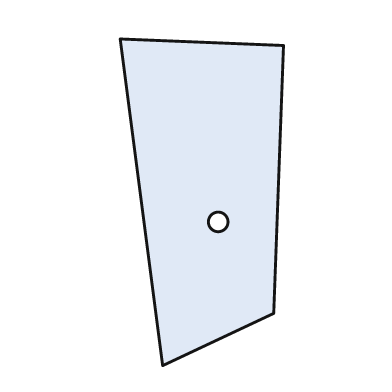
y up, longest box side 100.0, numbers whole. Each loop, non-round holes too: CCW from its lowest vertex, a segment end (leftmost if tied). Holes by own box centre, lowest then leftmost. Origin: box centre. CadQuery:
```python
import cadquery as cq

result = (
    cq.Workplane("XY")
    .moveTo(-12.0, -50.0)
    .lineTo(22.0, -34.0)
    .lineTo(25.0, 48.0)
    .lineTo(-25.0, 50.0)
    .close()
    .moveTo(5.0, -6.0)
    .circle(3.0)
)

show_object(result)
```